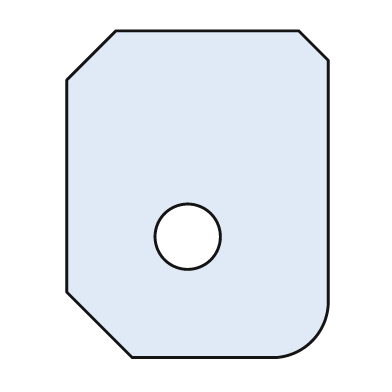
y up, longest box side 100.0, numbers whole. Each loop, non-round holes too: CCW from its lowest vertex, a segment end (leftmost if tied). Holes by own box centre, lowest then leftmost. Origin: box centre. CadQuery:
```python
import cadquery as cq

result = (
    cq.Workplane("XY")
    .moveTo(-20.0, -50.0)
    .lineTo(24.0, -50.0)
    .threePointArc((35.0, -45.0), (40.0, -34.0))
    .lineTo(40.0, 41.0)
    .lineTo(31.0, 50.0)
    .lineTo(-25.0, 50.0)
    .lineTo(-40.0, 35.0)
    .lineTo(-40.0, -30.0)
    .close()
    .moveTo(-3.0, -13.0)
    .circle(10.0)
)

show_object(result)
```